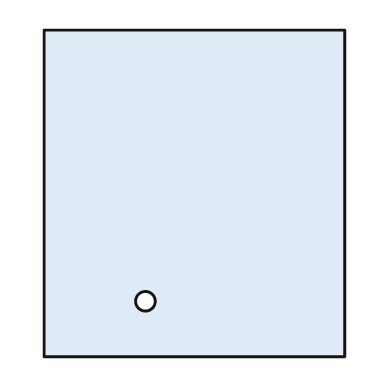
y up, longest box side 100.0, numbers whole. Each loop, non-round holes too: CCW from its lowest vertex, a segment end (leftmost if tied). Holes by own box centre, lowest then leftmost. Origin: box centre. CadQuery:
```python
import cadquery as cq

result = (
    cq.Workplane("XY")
    .moveTo(-46.0, -50.0)
    .lineTo(46.0, -50.0)
    .lineTo(46.0, 50.0)
    .lineTo(-46.0, 50.0)
    .close()
    .moveTo(-15.0, -33.0)
    .circle(3.0)
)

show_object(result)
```